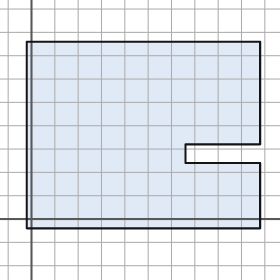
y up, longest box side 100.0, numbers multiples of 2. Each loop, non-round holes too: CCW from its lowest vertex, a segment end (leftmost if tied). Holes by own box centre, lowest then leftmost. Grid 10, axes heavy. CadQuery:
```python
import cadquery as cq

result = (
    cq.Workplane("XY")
    .moveTo(-2.0, -4.0)
    .lineTo(98.0, -4.0)
    .lineTo(98.0, 24.0)
    .lineTo(66.0, 24.0)
    .lineTo(66.0, 32.0)
    .lineTo(98.0, 32.0)
    .lineTo(98.0, 76.0)
    .lineTo(-2.0, 76.0)
    .close()
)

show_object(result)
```